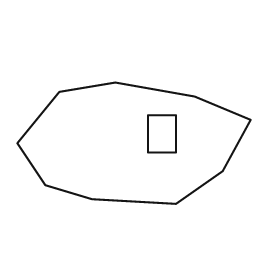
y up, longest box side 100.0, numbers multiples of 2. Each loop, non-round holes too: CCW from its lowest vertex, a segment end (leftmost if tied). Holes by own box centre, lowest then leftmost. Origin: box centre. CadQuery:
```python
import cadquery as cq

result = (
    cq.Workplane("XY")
    .moveTo(18.0, -26.0)
    .lineTo(38.0, -12.0)
    .lineTo(50.0, 10.0)
    .lineTo(26.0, 20.0)
    .lineTo(-8.0, 26.0)
    .lineTo(-32.0, 22.0)
    .lineTo(-50.0, 0.0)
    .lineTo(-38.0, -18.0)
    .lineTo(-18.0, -24.0)
    .close()
    .moveTo(6.0, -4.0)
    .lineTo(18.0, -4.0)
    .lineTo(18.0, 12.0)
    .lineTo(6.0, 12.0)
    .close()
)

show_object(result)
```